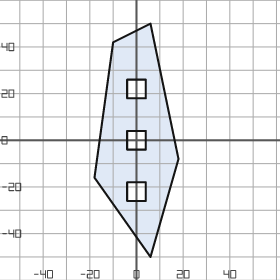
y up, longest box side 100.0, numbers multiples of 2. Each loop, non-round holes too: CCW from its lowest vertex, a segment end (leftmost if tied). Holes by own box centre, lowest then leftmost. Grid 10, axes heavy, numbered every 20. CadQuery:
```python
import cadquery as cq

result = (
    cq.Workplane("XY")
    .moveTo(6.0, -50.0)
    .lineTo(18.0, -8.0)
    .lineTo(6.0, 50.0)
    .lineTo(-10.0, 42.0)
    .lineTo(-18.0, -16.0)
    .close()
    .moveTo(-4.0, -26.0)
    .lineTo(4.0, -26.0)
    .lineTo(4.0, -18.0)
    .lineTo(-4.0, -18.0)
    .close()
    .moveTo(-4.0, -4.0)
    .lineTo(4.0, -4.0)
    .lineTo(4.0, 4.0)
    .lineTo(-4.0, 4.0)
    .close()
    .moveTo(-4.0, 18.0)
    .lineTo(4.0, 18.0)
    .lineTo(4.0, 26.0)
    .lineTo(-4.0, 26.0)
    .close()
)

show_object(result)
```